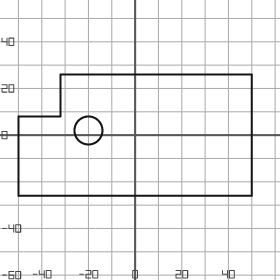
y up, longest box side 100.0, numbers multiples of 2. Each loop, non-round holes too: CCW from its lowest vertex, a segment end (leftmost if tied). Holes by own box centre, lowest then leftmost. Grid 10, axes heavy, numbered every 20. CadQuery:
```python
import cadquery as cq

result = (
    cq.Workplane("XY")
    .moveTo(-50.0, -26.0)
    .lineTo(50.0, -26.0)
    .lineTo(50.0, 26.0)
    .lineTo(-32.0, 26.0)
    .lineTo(-32.0, 8.0)
    .lineTo(-50.0, 8.0)
    .close()
    .moveTo(-20.0, 2.0)
    .circle(6.0)
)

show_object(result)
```